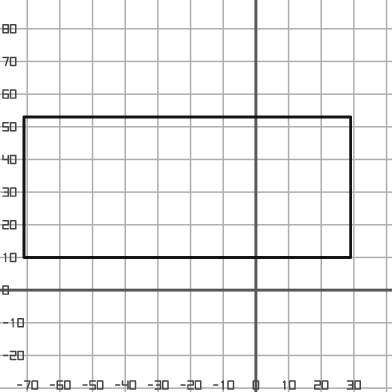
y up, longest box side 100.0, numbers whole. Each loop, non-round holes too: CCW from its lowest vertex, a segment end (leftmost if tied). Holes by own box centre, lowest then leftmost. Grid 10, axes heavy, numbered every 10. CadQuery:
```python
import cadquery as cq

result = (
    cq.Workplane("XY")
    .moveTo(-71.0, 10.0)
    .lineTo(29.0, 10.0)
    .lineTo(29.0, 53.0)
    .lineTo(-71.0, 53.0)
    .close()
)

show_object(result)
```